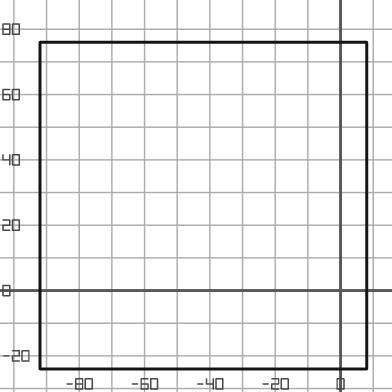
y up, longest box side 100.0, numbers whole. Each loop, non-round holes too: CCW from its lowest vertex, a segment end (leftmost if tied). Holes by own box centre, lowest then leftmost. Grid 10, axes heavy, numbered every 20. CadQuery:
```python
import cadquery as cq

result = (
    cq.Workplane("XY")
    .moveTo(-92.0, -24.0)
    .lineTo(8.0, -24.0)
    .lineTo(8.0, 76.0)
    .lineTo(-92.0, 76.0)
    .close()
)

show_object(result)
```